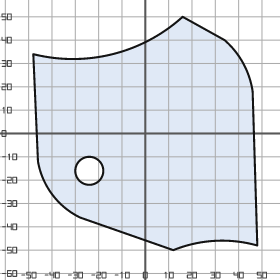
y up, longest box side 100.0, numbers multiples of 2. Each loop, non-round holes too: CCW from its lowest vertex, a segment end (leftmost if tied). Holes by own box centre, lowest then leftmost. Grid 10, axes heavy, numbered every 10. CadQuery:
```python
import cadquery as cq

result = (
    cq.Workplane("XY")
    .moveTo(12.0, -50.0)
    .threePointArc((30.0, -46.0), (48.0, -48.0))
    .lineTo(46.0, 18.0)
    .threePointArc((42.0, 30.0), (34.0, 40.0))
    .lineTo(16.0, 50.0)
    .threePointArc((-14.0, 34.0), (-48.0, 34.0))
    .lineTo(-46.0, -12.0)
    .threePointArc((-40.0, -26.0), (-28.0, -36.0))
    .close()
    .moveTo(-24.0, -16.0)
    .circle(6.0)
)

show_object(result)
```